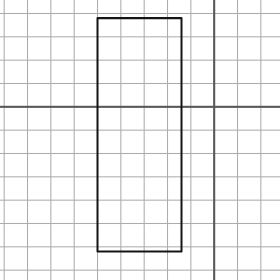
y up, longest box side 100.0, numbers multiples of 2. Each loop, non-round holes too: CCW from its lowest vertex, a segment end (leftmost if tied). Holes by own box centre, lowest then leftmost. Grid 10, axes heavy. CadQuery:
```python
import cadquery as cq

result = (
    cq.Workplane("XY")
    .moveTo(-50.0, -62.0)
    .lineTo(-14.0, -62.0)
    .lineTo(-14.0, 38.0)
    .lineTo(-50.0, 38.0)
    .close()
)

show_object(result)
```